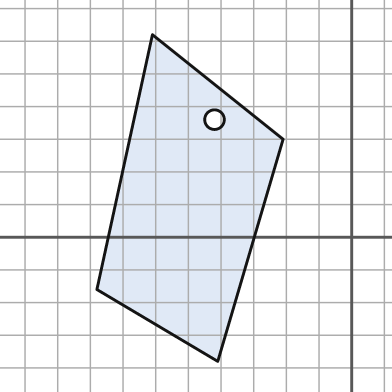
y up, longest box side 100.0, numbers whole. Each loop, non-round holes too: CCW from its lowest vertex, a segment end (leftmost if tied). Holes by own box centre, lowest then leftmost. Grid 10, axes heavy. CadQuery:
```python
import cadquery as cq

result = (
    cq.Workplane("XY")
    .moveTo(-41.0, -38.0)
    .lineTo(-21.0, 30.0)
    .lineTo(-61.0, 62.0)
    .lineTo(-78.0, -16.0)
    .close()
    .moveTo(-42.0, 36.0)
    .circle(3.0)
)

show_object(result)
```